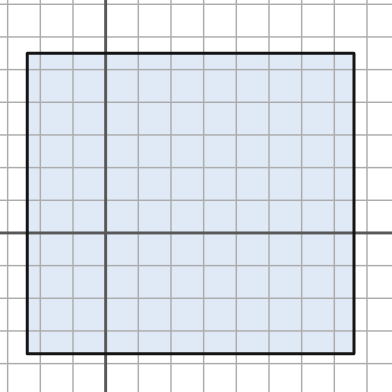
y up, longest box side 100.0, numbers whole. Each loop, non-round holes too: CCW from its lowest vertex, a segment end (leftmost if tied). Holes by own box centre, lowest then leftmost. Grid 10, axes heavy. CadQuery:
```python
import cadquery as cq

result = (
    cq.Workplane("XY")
    .moveTo(-24.0, -37.0)
    .lineTo(76.0, -37.0)
    .lineTo(76.0, 55.0)
    .lineTo(-24.0, 55.0)
    .close()
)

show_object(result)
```